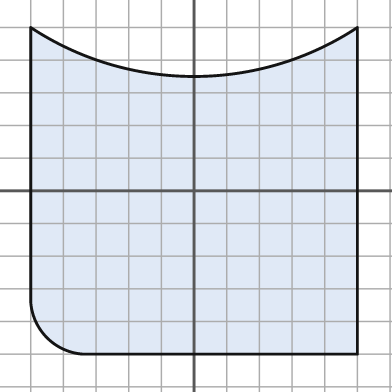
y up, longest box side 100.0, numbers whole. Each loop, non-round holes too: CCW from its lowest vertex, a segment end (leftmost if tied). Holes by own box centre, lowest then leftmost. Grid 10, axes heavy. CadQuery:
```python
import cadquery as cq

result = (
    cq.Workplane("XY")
    .moveTo(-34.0, -50.0)
    .lineTo(50.0, -50.0)
    .lineTo(50.0, 50.0)
    .threePointArc((0.0, 35.0), (-50.0, 50.0))
    .lineTo(-50.0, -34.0)
    .threePointArc((-45.0, -45.0), (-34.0, -50.0))
    .close()
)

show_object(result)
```